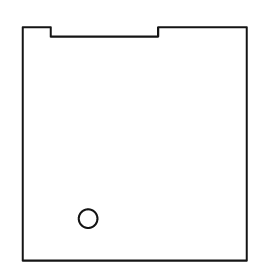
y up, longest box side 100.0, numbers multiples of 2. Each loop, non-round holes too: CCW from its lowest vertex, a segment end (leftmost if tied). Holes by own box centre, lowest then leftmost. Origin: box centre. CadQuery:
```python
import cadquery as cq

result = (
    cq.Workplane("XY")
    .moveTo(-48.0, -50.0)
    .lineTo(48.0, -50.0)
    .lineTo(48.0, 50.0)
    .lineTo(10.0, 50.0)
    .lineTo(10.0, 46.0)
    .lineTo(-36.0, 46.0)
    .lineTo(-36.0, 50.0)
    .lineTo(-48.0, 50.0)
    .close()
    .moveTo(-20.0, -32.0)
    .circle(4.0)
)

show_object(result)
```